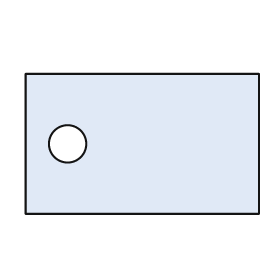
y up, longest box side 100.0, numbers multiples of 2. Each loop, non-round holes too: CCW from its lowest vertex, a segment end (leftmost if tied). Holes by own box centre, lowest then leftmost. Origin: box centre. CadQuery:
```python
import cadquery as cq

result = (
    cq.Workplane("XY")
    .moveTo(-50.0, -30.0)
    .lineTo(50.0, -30.0)
    .lineTo(50.0, 30.0)
    .lineTo(-50.0, 30.0)
    .close()
    .moveTo(-32.0, 0.0)
    .circle(8.0)
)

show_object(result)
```